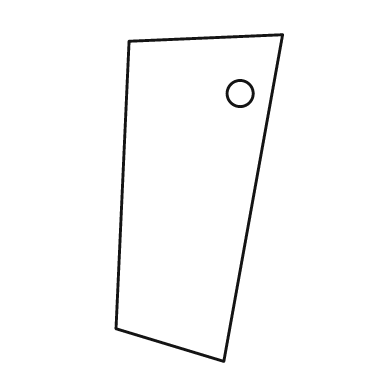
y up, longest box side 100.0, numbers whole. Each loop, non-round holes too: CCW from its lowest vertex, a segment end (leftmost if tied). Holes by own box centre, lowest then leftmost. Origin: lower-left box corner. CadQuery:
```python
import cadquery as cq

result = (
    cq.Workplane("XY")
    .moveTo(33.0, 0.0)
    .lineTo(51.0, 100.0)
    .lineTo(4.0, 98.0)
    .lineTo(0.0, 10.0)
    .close()
    .moveTo(38.0, 82.0)
    .circle(4.0)
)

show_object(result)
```